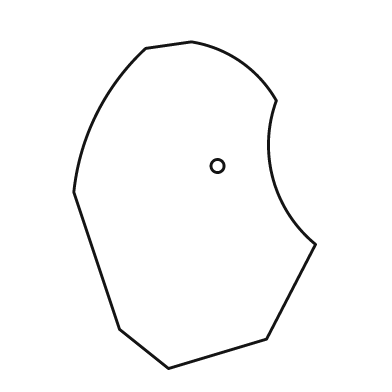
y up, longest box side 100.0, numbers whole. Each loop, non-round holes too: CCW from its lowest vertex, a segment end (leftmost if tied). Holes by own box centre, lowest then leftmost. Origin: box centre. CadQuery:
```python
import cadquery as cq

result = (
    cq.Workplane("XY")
    .moveTo(-8.0, -50.0)
    .lineTo(22.0, -41.0)
    .lineTo(37.0, -12.0)
    .threePointArc((24.0, 8.0), (25.0, 32.0))
    .threePointArc((14.0, 44.0), (-1.0, 50.0))
    .lineTo(-15.0, 48.0)
    .threePointArc((-30.0, 28.0), (-37.0, 4.0))
    .lineTo(-23.0, -38.0)
    .close()
    .moveTo(7.0, 12.0)
    .circle(2.0)
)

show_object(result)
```